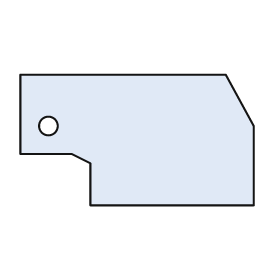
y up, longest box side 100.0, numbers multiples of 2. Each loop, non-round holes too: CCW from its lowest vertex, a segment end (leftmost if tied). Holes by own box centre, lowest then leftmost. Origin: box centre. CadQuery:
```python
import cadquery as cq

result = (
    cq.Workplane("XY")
    .moveTo(-20.0, -28.0)
    .lineTo(50.0, -28.0)
    .lineTo(50.0, 6.0)
    .lineTo(38.0, 28.0)
    .lineTo(-50.0, 28.0)
    .lineTo(-50.0, -6.0)
    .lineTo(-28.0, -6.0)
    .lineTo(-20.0, -10.0)
    .close()
    .moveTo(-38.0, 6.0)
    .circle(4.0)
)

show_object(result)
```